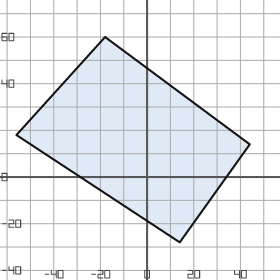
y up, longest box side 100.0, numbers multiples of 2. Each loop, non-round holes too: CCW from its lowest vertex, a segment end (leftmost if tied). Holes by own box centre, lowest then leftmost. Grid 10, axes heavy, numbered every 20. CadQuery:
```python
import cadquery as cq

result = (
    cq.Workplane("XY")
    .moveTo(14.0, -28.0)
    .lineTo(44.0, 14.0)
    .lineTo(-18.0, 60.0)
    .lineTo(-56.0, 18.0)
    .close()
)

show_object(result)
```